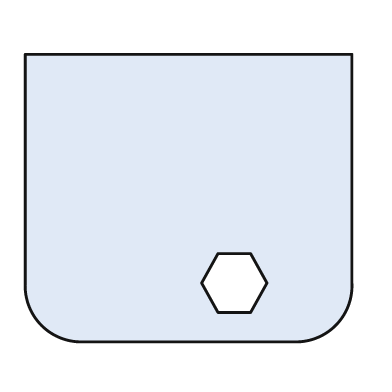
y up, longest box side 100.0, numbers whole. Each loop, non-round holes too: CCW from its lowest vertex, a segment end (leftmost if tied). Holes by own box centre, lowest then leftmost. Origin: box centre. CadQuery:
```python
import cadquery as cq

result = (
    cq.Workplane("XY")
    .moveTo(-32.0, -44.0)
    .lineTo(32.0, -44.0)
    .threePointArc((45.0, -39.0), (50.0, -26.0))
    .lineTo(50.0, 44.0)
    .lineTo(-50.0, 44.0)
    .lineTo(-50.0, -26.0)
    .threePointArc((-45.0, -39.0), (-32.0, -44.0))
    .close()
    .moveTo(9.0, -35.0)
    .lineTo(19.0, -35.0)
    .lineTo(24.0, -26.0)
    .lineTo(19.0, -17.0)
    .lineTo(9.0, -17.0)
    .lineTo(4.0, -26.0)
    .close()
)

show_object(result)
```